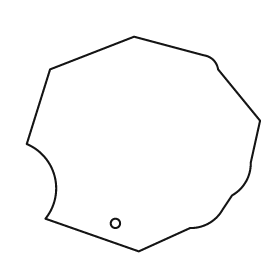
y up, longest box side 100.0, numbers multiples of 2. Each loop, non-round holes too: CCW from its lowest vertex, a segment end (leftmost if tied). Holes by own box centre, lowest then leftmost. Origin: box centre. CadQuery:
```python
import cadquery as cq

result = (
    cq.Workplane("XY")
    .moveTo(-2.0, -46.0)
    .lineTo(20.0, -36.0)
    .threePointArc((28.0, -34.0), (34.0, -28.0))
    .lineTo(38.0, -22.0)
    .threePointArc((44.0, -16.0), (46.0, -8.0))
    .lineTo(50.0, 10.0)
    .lineTo(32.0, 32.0)
    .threePointArc((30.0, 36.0), (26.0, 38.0))
    .lineTo(-4.0, 46.0)
    .lineTo(-40.0, 32.0)
    .lineTo(-50.0, 0.0)
    .threePointArc((-38.0, -14.0), (-42.0, -32.0))
    .close()
    .moveTo(-12.0, -34.0)
    .circle(2.0)
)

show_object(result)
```